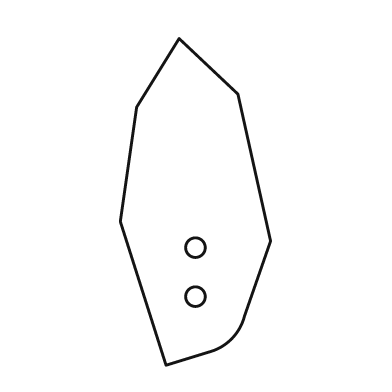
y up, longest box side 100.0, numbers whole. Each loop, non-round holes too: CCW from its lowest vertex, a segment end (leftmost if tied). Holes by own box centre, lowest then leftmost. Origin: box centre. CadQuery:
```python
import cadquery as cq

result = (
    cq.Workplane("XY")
    .moveTo(-9.0, -50.0)
    .lineTo(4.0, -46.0)
    .threePointArc((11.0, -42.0), (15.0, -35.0))
    .lineTo(23.0, -12.0)
    .lineTo(13.0, 33.0)
    .lineTo(-5.0, 50.0)
    .lineTo(-18.0, 29.0)
    .lineTo(-23.0, -6.0)
    .close()
    .moveTo(0.0, -29.0)
    .circle(3.0)
    .moveTo(0.0, -14.0)
    .circle(3.0)
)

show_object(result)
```